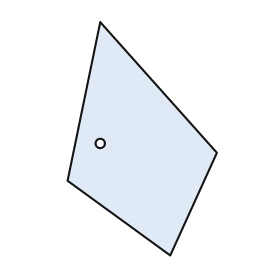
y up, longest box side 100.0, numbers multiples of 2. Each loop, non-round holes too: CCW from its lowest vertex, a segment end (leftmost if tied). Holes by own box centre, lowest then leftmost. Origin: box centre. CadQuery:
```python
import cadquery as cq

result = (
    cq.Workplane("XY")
    .moveTo(12.0, -50.0)
    .lineTo(32.0, -6.0)
    .lineTo(-18.0, 50.0)
    .lineTo(-32.0, -18.0)
    .close()
    .moveTo(-18.0, -2.0)
    .circle(2.0)
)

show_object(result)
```